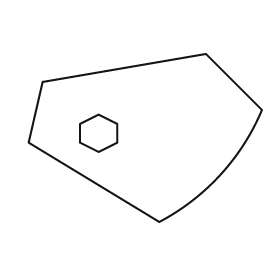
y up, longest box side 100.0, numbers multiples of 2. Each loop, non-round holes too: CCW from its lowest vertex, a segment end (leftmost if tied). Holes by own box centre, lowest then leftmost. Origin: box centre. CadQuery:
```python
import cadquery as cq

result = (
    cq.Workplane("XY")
    .moveTo(6.0, -36.0)
    .threePointArc((32.0, -16.0), (50.0, 12.0))
    .lineTo(26.0, 36.0)
    .lineTo(-44.0, 24.0)
    .lineTo(-50.0, -2.0)
    .close()
    .moveTo(-20.0, -6.0)
    .lineTo(-12.0, -2.0)
    .lineTo(-12.0, 6.0)
    .lineTo(-20.0, 10.0)
    .lineTo(-28.0, 6.0)
    .lineTo(-28.0, -2.0)
    .close()
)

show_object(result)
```